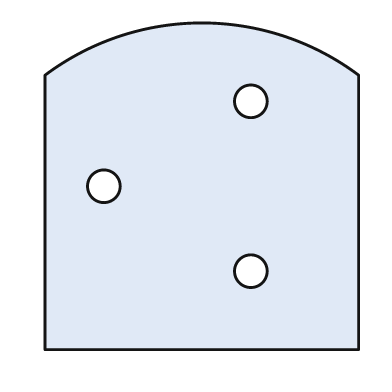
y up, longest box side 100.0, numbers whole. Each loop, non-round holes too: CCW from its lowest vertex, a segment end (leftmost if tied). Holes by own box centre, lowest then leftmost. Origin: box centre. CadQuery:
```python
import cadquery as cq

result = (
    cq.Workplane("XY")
    .moveTo(-48.0, -50.0)
    .lineTo(48.0, -50.0)
    .lineTo(48.0, 34.0)
    .threePointArc((0.0, 50.0), (-48.0, 34.0))
    .close()
    .moveTo(15.0, -26.0)
    .circle(5.0)
    .moveTo(-30.0, 0.0)
    .circle(5.0)
    .moveTo(15.0, 26.0)
    .circle(5.0)
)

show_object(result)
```